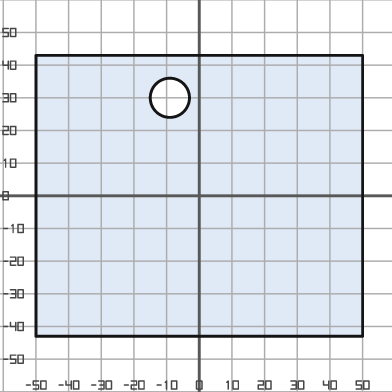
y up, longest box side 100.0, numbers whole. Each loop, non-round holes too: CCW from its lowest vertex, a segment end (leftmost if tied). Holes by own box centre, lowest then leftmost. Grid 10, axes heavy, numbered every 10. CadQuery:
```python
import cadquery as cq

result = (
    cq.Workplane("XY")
    .moveTo(-50.0, -43.0)
    .lineTo(50.0, -43.0)
    .lineTo(50.0, 43.0)
    .lineTo(-50.0, 43.0)
    .close()
    .moveTo(-9.0, 30.0)
    .circle(6.0)
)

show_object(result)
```